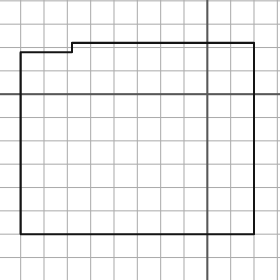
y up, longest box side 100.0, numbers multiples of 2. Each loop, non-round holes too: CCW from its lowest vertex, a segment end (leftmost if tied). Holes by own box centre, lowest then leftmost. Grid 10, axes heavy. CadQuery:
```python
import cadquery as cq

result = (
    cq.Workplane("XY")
    .moveTo(-80.0, -60.0)
    .lineTo(20.0, -60.0)
    .lineTo(20.0, 22.0)
    .lineTo(-58.0, 22.0)
    .lineTo(-58.0, 18.0)
    .lineTo(-80.0, 18.0)
    .close()
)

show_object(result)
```